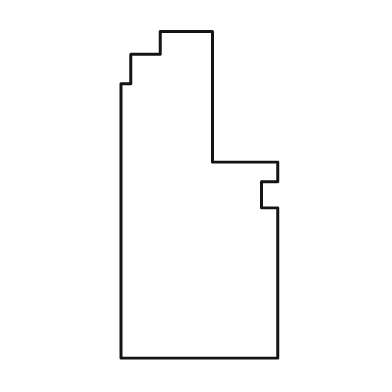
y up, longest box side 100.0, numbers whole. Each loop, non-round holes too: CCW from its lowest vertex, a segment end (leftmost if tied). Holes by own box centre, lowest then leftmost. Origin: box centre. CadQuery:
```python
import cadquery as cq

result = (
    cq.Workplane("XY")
    .moveTo(-24.0, -50.0)
    .lineTo(24.0, -50.0)
    .lineTo(24.0, -4.0)
    .lineTo(19.0, -4.0)
    .lineTo(19.0, 4.0)
    .lineTo(24.0, 4.0)
    .lineTo(24.0, 10.0)
    .lineTo(4.0, 10.0)
    .lineTo(4.0, 50.0)
    .lineTo(-12.0, 50.0)
    .lineTo(-12.0, 43.0)
    .lineTo(-21.0, 43.0)
    .lineTo(-21.0, 34.0)
    .lineTo(-24.0, 34.0)
    .close()
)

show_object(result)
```